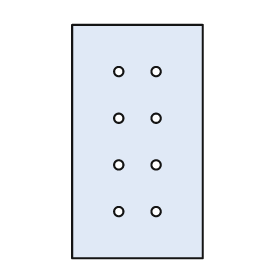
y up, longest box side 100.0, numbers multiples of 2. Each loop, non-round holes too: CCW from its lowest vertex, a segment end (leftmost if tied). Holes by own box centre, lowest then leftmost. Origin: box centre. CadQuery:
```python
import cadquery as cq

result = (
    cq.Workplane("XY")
    .moveTo(-28.0, -50.0)
    .lineTo(28.0, -50.0)
    .lineTo(28.0, 50.0)
    .lineTo(-28.0, 50.0)
    .close()
    .moveTo(-8.0, -30.0)
    .circle(2.0)
    .moveTo(8.0, -30.0)
    .circle(2.0)
    .moveTo(-8.0, -10.0)
    .circle(2.0)
    .moveTo(8.0, -10.0)
    .circle(2.0)
    .moveTo(-8.0, 10.0)
    .circle(2.0)
    .moveTo(8.0, 10.0)
    .circle(2.0)
    .moveTo(-8.0, 30.0)
    .circle(2.0)
    .moveTo(8.0, 30.0)
    .circle(2.0)
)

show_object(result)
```